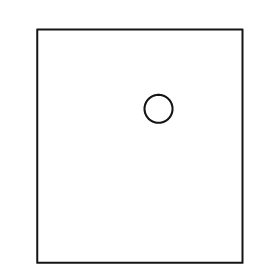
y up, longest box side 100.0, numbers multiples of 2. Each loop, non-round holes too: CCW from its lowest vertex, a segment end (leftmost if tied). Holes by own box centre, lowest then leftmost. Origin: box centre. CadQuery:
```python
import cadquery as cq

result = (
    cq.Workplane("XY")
    .moveTo(-44.0, -50.0)
    .lineTo(44.0, -50.0)
    .lineTo(44.0, 50.0)
    .lineTo(-44.0, 50.0)
    .close()
    .moveTo(8.0, 16.0)
    .circle(6.0)
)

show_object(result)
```